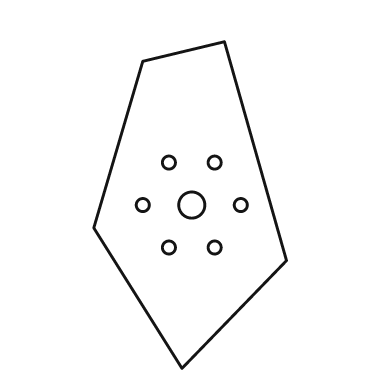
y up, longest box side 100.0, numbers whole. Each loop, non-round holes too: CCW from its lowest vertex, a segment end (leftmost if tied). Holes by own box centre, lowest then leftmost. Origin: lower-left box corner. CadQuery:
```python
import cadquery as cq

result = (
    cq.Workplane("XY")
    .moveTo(27.0, 0.0)
    .lineTo(59.0, 33.0)
    .lineTo(40.0, 100.0)
    .lineTo(15.0, 94.0)
    .lineTo(0.0, 43.0)
    .close()
    .moveTo(23.0, 37.0)
    .circle(2.0)
    .moveTo(37.0, 37.0)
    .circle(2.0)
    .moveTo(15.0, 50.0)
    .circle(2.0)
    .moveTo(30.0, 50.0)
    .circle(4.0)
    .moveTo(45.0, 50.0)
    .circle(2.0)
    .moveTo(23.0, 63.0)
    .circle(2.0)
    .moveTo(37.0, 63.0)
    .circle(2.0)
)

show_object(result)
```